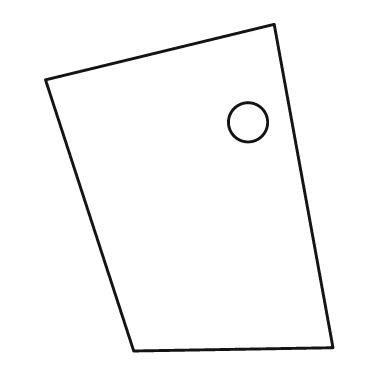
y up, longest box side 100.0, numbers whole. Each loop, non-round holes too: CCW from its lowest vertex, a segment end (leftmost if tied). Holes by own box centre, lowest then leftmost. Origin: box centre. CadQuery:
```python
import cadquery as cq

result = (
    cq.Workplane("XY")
    .moveTo(-17.0, -50.0)
    .lineTo(44.0, -49.0)
    .lineTo(26.0, 50.0)
    .lineTo(-44.0, 33.0)
    .close()
    .moveTo(18.0, 20.0)
    .circle(6.0)
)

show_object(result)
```